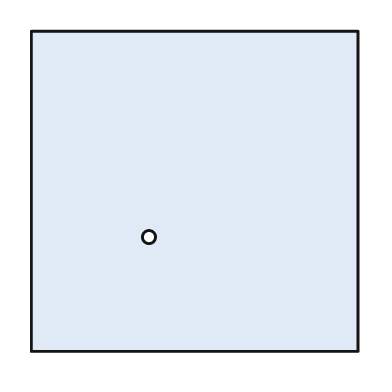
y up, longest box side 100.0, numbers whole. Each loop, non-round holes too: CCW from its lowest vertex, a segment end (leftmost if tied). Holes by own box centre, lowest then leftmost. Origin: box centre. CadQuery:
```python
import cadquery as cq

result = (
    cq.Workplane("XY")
    .moveTo(-50.0, -49.0)
    .lineTo(50.0, -49.0)
    .lineTo(50.0, 49.0)
    .lineTo(-50.0, 49.0)
    .close()
    .moveTo(-14.0, -14.0)
    .circle(2.0)
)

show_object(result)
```